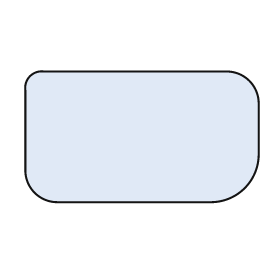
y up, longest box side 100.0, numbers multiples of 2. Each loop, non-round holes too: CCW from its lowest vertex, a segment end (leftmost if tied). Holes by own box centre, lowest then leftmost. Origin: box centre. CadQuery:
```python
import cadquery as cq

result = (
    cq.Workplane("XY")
    .moveTo(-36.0, -28.0)
    .lineTo(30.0, -28.0)
    .threePointArc((44.0, -22.0), (50.0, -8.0))
    .lineTo(50.0, 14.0)
    .threePointArc((46.0, 24.0), (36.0, 28.0))
    .lineTo(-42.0, 28.0)
    .threePointArc((-48.0, 26.0), (-50.0, 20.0))
    .lineTo(-50.0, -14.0)
    .threePointArc((-46.0, -24.0), (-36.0, -28.0))
    .close()
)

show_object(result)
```